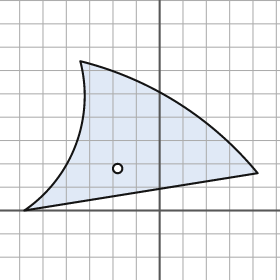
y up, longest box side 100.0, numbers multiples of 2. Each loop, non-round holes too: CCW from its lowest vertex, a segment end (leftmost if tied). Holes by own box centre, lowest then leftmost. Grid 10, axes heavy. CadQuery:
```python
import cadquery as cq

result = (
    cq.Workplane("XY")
    .moveTo(-58.0, 0.0)
    .lineTo(42.0, 16.0)
    .threePointArc((8.0, 46.0), (-34.0, 64.0))
    .threePointArc((-36.0, 28.0), (-58.0, 0.0))
    .close()
    .moveTo(-18.0, 18.0)
    .circle(2.0)
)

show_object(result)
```